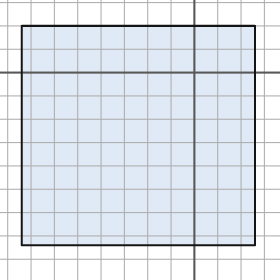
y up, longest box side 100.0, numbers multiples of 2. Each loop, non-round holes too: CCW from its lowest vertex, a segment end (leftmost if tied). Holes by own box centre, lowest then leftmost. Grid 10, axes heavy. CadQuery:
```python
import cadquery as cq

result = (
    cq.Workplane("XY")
    .moveTo(-74.0, -74.0)
    .lineTo(26.0, -74.0)
    .lineTo(26.0, 20.0)
    .lineTo(-74.0, 20.0)
    .close()
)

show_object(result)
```